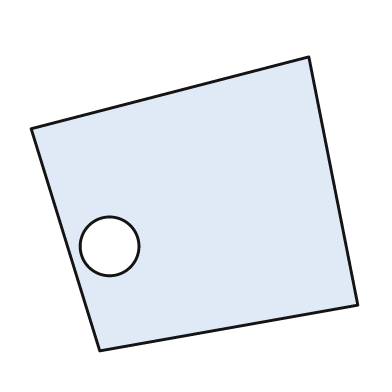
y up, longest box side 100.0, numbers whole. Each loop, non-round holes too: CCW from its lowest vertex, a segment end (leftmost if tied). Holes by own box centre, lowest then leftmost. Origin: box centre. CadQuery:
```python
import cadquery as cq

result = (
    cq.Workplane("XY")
    .moveTo(-29.0, -45.0)
    .lineTo(50.0, -31.0)
    .lineTo(35.0, 45.0)
    .lineTo(-50.0, 23.0)
    .close()
    .moveTo(-26.0, -13.0)
    .circle(9.0)
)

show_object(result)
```